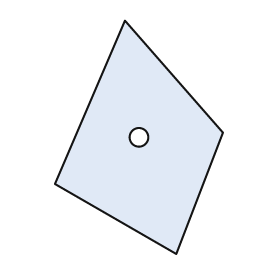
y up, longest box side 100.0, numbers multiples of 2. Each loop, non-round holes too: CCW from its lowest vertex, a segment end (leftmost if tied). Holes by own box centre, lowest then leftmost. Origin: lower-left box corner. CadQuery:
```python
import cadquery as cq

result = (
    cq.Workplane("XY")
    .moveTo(52.0, 0.0)
    .lineTo(72.0, 52.0)
    .lineTo(30.0, 100.0)
    .lineTo(0.0, 30.0)
    .close()
    .moveTo(36.0, 50.0)
    .circle(4.0)
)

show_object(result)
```